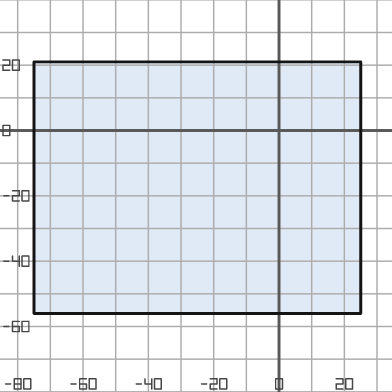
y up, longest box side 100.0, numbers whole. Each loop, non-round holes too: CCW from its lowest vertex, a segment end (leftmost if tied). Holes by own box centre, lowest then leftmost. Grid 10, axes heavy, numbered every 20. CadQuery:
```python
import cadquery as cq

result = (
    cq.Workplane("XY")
    .moveTo(-75.0, -56.0)
    .lineTo(25.0, -56.0)
    .lineTo(25.0, 21.0)
    .lineTo(-75.0, 21.0)
    .close()
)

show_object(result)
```